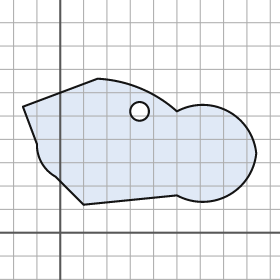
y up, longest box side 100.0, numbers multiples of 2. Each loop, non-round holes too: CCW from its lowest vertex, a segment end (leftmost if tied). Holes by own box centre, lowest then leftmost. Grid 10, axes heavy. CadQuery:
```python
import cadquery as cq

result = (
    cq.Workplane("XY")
    .moveTo(10.0, 12.0)
    .lineTo(50.0, 16.0)
    .threePointArc((72.0, 16.0), (84.0, 34.0))
    .threePointArc((72.0, 52.0), (50.0, 52.0))
    .threePointArc((34.0, 62.0), (16.0, 66.0))
    .lineTo(-16.0, 54.0)
    .lineTo(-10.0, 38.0)
    .threePointArc((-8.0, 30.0), (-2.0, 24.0))
    .close()
    .moveTo(34.0, 52.0)
    .circle(4.0)
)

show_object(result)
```